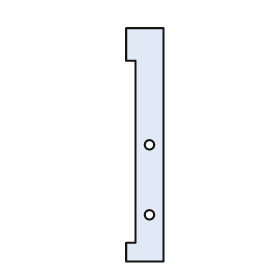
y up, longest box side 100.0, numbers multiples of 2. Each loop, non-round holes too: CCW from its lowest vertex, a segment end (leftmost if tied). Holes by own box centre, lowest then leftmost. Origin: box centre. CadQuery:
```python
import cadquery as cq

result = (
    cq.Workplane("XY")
    .moveTo(-8.0, -50.0)
    .lineTo(8.0, -50.0)
    .lineTo(8.0, 50.0)
    .lineTo(-8.0, 50.0)
    .lineTo(-8.0, 36.0)
    .lineTo(-4.0, 36.0)
    .lineTo(-4.0, -42.0)
    .lineTo(-8.0, -42.0)
    .close()
    .moveTo(2.0, -30.0)
    .circle(2.0)
    .moveTo(2.0, 0.0)
    .circle(2.0)
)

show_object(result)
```